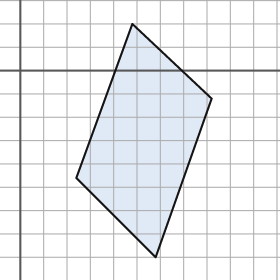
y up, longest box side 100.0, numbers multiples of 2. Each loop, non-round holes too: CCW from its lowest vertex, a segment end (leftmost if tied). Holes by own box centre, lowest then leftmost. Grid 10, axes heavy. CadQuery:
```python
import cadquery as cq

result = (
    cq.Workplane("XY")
    .moveTo(58.0, -80.0)
    .lineTo(82.0, -12.0)
    .lineTo(48.0, 20.0)
    .lineTo(24.0, -46.0)
    .close()
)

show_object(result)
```